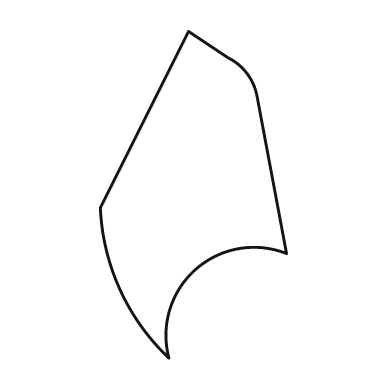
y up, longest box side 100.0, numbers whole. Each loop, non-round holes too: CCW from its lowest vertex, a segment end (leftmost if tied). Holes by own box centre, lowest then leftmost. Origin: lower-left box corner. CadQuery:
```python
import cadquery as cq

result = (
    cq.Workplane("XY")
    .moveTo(21.0, 0.0)
    .threePointArc((29.0, 27.0), (57.0, 32.0))
    .lineTo(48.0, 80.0)
    .threePointArc((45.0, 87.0), (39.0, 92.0))
    .lineTo(27.0, 100.0)
    .lineTo(0.0, 46.0)
    .threePointArc((6.0, 21.0), (21.0, 0.0))
    .close()
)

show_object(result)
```